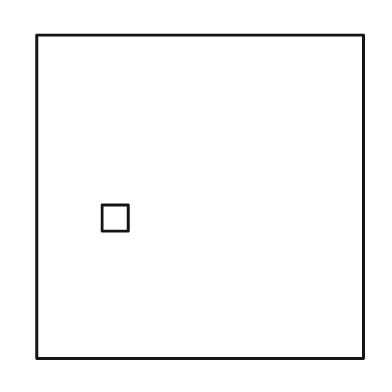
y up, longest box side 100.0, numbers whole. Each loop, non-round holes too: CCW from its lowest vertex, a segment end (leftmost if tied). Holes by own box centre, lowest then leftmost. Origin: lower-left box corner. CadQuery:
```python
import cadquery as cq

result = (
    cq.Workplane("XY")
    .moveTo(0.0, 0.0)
    .lineTo(100.0, 0.0)
    .lineTo(100.0, 99.0)
    .lineTo(0.0, 99.0)
    .close()
    .moveTo(20.0, 39.0)
    .lineTo(28.0, 39.0)
    .lineTo(28.0, 47.0)
    .lineTo(20.0, 47.0)
    .close()
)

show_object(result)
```